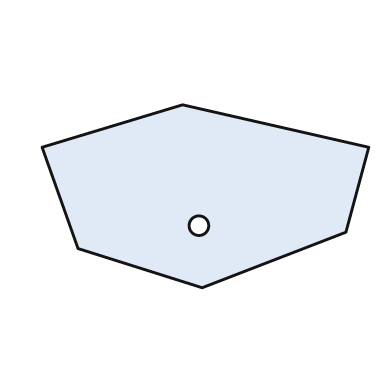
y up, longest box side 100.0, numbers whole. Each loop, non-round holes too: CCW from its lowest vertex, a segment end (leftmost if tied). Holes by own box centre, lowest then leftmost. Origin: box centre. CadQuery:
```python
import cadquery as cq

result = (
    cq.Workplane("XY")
    .moveTo(-1.0, -28.0)
    .lineTo(43.0, -11.0)
    .lineTo(50.0, 15.0)
    .lineTo(-7.0, 28.0)
    .lineTo(-50.0, 15.0)
    .lineTo(-39.0, -16.0)
    .close()
    .moveTo(-2.0, -9.0)
    .circle(3.0)
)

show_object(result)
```